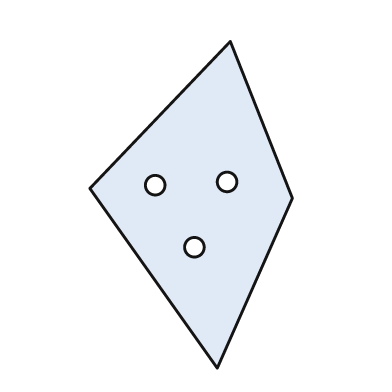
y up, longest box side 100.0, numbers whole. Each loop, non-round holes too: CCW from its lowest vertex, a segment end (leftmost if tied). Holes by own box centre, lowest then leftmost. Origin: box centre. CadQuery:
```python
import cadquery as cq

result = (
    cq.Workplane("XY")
    .moveTo(8.0, -50.0)
    .lineTo(31.0, 2.0)
    .lineTo(12.0, 50.0)
    .lineTo(-31.0, 5.0)
    .close()
    .moveTo(1.0, -13.0)
    .circle(3.0)
    .moveTo(-11.0, 6.0)
    .circle(3.0)
    .moveTo(11.0, 7.0)
    .circle(3.0)
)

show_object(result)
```